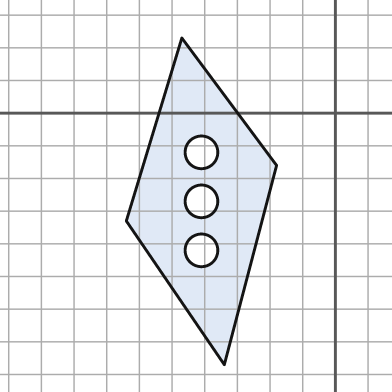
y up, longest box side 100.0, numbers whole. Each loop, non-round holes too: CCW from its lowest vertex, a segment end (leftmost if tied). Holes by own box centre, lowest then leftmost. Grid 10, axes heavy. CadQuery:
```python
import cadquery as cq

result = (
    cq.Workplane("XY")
    .moveTo(-34.0, -77.0)
    .lineTo(-18.0, -16.0)
    .lineTo(-47.0, 23.0)
    .lineTo(-64.0, -33.0)
    .close()
    .moveTo(-41.0, -42.0)
    .circle(5.0)
    .moveTo(-41.0, -27.0)
    .circle(5.0)
    .moveTo(-41.0, -12.0)
    .circle(5.0)
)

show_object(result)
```